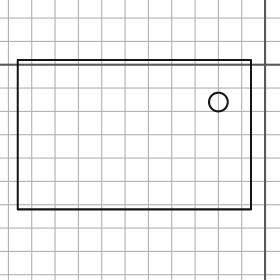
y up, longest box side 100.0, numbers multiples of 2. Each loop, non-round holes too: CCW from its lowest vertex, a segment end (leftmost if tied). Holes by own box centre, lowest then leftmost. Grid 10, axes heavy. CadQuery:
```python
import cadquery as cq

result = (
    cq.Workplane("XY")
    .moveTo(-106.0, -62.0)
    .lineTo(-6.0, -62.0)
    .lineTo(-6.0, 2.0)
    .lineTo(-106.0, 2.0)
    .close()
    .moveTo(-20.0, -16.0)
    .circle(4.0)
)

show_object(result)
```